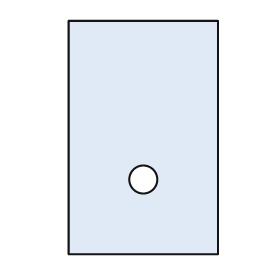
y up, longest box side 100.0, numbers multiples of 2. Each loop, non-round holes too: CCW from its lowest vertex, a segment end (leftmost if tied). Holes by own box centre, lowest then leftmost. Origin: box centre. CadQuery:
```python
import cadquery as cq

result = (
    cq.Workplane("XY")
    .moveTo(-32.0, -50.0)
    .lineTo(32.0, -50.0)
    .lineTo(32.0, 50.0)
    .lineTo(-32.0, 50.0)
    .close()
    .moveTo(0.0, -18.0)
    .circle(6.0)
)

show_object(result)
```